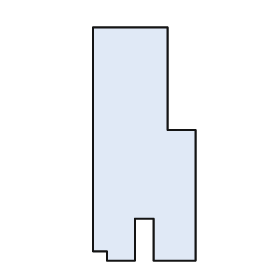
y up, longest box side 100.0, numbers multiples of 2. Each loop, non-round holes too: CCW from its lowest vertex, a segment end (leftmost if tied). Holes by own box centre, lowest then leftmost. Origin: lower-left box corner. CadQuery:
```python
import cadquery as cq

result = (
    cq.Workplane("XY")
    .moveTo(6.0, 0.0)
    .lineTo(18.0, 0.0)
    .lineTo(18.0, 18.0)
    .lineTo(26.0, 18.0)
    .lineTo(26.0, 0.0)
    .lineTo(44.0, 0.0)
    .lineTo(44.0, 56.0)
    .lineTo(32.0, 56.0)
    .lineTo(32.0, 100.0)
    .lineTo(0.0, 100.0)
    .lineTo(0.0, 4.0)
    .lineTo(6.0, 4.0)
    .close()
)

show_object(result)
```